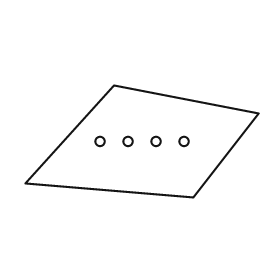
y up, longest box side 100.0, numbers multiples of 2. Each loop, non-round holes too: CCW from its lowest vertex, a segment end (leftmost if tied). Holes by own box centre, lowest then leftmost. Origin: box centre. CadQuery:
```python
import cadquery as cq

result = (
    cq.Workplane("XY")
    .moveTo(22.0, -24.0)
    .lineTo(50.0, 12.0)
    .lineTo(-12.0, 24.0)
    .lineTo(-50.0, -18.0)
    .close()
    .moveTo(-18.0, 0.0)
    .circle(2.0)
    .moveTo(-6.0, 0.0)
    .circle(2.0)
    .moveTo(6.0, 0.0)
    .circle(2.0)
    .moveTo(18.0, 0.0)
    .circle(2.0)
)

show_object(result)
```